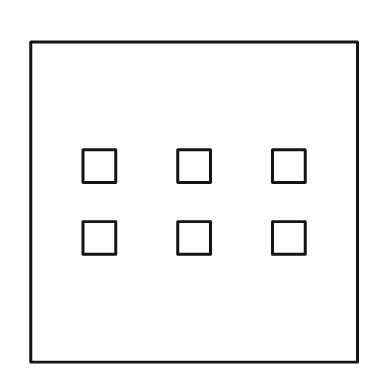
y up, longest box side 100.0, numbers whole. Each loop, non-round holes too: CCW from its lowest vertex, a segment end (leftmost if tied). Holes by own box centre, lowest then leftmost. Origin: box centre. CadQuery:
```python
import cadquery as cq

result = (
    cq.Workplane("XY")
    .moveTo(-50.0, -49.0)
    .lineTo(50.0, -49.0)
    .lineTo(50.0, 49.0)
    .lineTo(-50.0, 49.0)
    .close()
    .moveTo(-34.0, -16.0)
    .lineTo(-24.0, -16.0)
    .lineTo(-24.0, -6.0)
    .lineTo(-34.0, -6.0)
    .close()
    .moveTo(-5.0, -16.0)
    .lineTo(5.0, -16.0)
    .lineTo(5.0, -6.0)
    .lineTo(-5.0, -6.0)
    .close()
    .moveTo(24.0, -16.0)
    .lineTo(34.0, -16.0)
    .lineTo(34.0, -6.0)
    .lineTo(24.0, -6.0)
    .close()
    .moveTo(-34.0, 6.0)
    .lineTo(-24.0, 6.0)
    .lineTo(-24.0, 16.0)
    .lineTo(-34.0, 16.0)
    .close()
    .moveTo(-5.0, 6.0)
    .lineTo(5.0, 6.0)
    .lineTo(5.0, 16.0)
    .lineTo(-5.0, 16.0)
    .close()
    .moveTo(24.0, 6.0)
    .lineTo(34.0, 6.0)
    .lineTo(34.0, 16.0)
    .lineTo(24.0, 16.0)
    .close()
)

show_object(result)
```